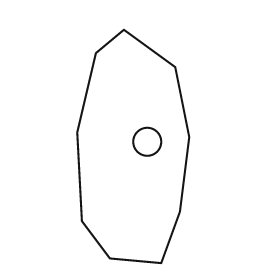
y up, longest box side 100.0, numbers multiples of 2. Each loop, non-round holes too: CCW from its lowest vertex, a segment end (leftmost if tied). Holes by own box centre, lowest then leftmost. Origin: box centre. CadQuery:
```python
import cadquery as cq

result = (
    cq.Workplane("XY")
    .moveTo(12.0, -50.0)
    .lineTo(20.0, -28.0)
    .lineTo(24.0, 4.0)
    .lineTo(18.0, 34.0)
    .lineTo(-4.0, 50.0)
    .lineTo(-16.0, 40.0)
    .lineTo(-24.0, 6.0)
    .lineTo(-22.0, -32.0)
    .lineTo(-10.0, -48.0)
    .close()
    .moveTo(6.0, 2.0)
    .circle(6.0)
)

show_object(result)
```